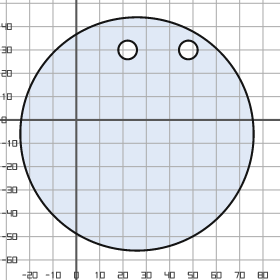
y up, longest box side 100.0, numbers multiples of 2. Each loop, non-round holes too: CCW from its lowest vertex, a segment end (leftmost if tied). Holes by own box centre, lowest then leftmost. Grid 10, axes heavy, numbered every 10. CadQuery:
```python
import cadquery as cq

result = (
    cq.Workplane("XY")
    .moveTo(26.0, -6.0)
    .circle(50.0)
    .moveTo(22.0, 30.0)
    .circle(4.0)
    .moveTo(48.0, 30.0)
    .circle(4.0)
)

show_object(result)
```